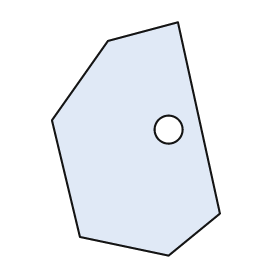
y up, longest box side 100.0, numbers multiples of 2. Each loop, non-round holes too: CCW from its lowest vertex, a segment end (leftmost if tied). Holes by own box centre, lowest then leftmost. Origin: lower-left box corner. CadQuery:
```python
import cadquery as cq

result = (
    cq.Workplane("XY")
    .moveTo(50.0, 0.0)
    .lineTo(72.0, 18.0)
    .lineTo(54.0, 100.0)
    .lineTo(24.0, 92.0)
    .lineTo(0.0, 58.0)
    .lineTo(12.0, 8.0)
    .close()
    .moveTo(50.0, 54.0)
    .circle(6.0)
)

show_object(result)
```